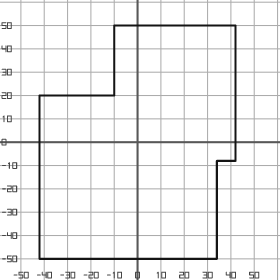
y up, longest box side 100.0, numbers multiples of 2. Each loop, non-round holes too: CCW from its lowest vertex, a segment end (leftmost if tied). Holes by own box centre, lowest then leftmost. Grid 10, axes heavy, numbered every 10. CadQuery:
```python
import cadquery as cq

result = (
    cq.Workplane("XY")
    .moveTo(-42.0, -50.0)
    .lineTo(34.0, -50.0)
    .lineTo(34.0, -8.0)
    .lineTo(42.0, -8.0)
    .lineTo(42.0, 50.0)
    .lineTo(-10.0, 50.0)
    .lineTo(-10.0, 20.0)
    .lineTo(-42.0, 20.0)
    .close()
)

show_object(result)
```